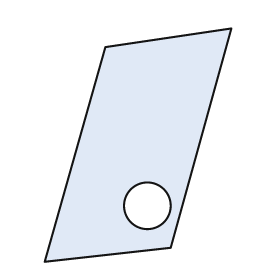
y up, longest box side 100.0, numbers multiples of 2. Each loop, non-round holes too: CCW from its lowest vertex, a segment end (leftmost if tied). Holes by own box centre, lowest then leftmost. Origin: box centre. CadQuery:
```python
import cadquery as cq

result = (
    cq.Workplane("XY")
    .moveTo(-40.0, -50.0)
    .lineTo(14.0, -44.0)
    .lineTo(40.0, 50.0)
    .lineTo(-14.0, 42.0)
    .close()
    .moveTo(4.0, -26.0)
    .circle(10.0)
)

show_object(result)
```